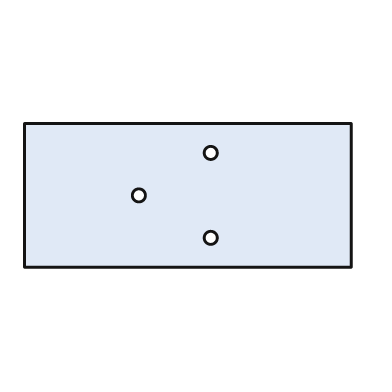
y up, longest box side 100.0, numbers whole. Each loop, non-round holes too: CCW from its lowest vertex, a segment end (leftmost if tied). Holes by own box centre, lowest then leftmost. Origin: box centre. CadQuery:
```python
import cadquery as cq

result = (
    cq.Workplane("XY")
    .moveTo(-50.0, -22.0)
    .lineTo(50.0, -22.0)
    .lineTo(50.0, 22.0)
    .lineTo(-50.0, 22.0)
    .close()
    .moveTo(7.0, -13.0)
    .circle(2.0)
    .moveTo(-15.0, 0.0)
    .circle(2.0)
    .moveTo(7.0, 13.0)
    .circle(2.0)
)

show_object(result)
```